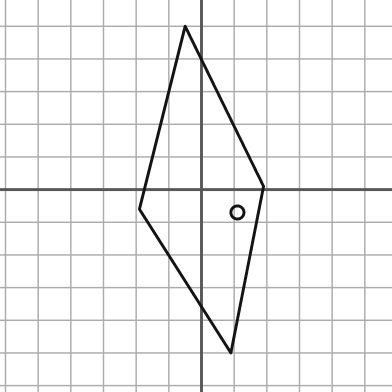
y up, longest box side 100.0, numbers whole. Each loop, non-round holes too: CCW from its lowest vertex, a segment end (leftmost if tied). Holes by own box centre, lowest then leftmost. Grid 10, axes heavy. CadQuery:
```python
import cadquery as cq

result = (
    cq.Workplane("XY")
    .moveTo(9.0, -50.0)
    .lineTo(19.0, 1.0)
    .lineTo(-5.0, 50.0)
    .lineTo(-19.0, -6.0)
    .close()
    .moveTo(11.0, -7.0)
    .circle(2.0)
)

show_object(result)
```